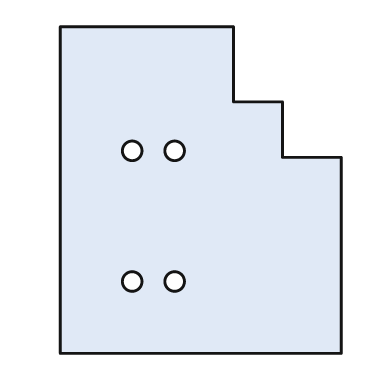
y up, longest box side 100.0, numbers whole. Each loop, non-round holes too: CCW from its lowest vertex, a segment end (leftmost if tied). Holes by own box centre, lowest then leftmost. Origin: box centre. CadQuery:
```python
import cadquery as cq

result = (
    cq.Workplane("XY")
    .moveTo(-43.0, -50.0)
    .lineTo(43.0, -50.0)
    .lineTo(43.0, 10.0)
    .lineTo(25.0, 10.0)
    .lineTo(25.0, 27.0)
    .lineTo(10.0, 27.0)
    .lineTo(10.0, 50.0)
    .lineTo(-43.0, 50.0)
    .close()
    .moveTo(-21.0, -28.0)
    .circle(3.0)
    .moveTo(-8.0, -28.0)
    .circle(3.0)
    .moveTo(-21.0, 12.0)
    .circle(3.0)
    .moveTo(-8.0, 12.0)
    .circle(3.0)
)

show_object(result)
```